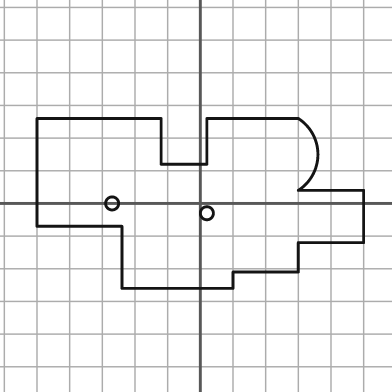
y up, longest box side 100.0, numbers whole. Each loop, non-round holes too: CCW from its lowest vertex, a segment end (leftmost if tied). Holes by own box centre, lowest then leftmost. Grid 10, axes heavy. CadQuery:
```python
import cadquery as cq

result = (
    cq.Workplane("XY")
    .moveTo(-24.0, -26.0)
    .lineTo(10.0, -26.0)
    .lineTo(10.0, -21.0)
    .lineTo(30.0, -21.0)
    .lineTo(30.0, -12.0)
    .lineTo(50.0, -12.0)
    .lineTo(50.0, 4.0)
    .lineTo(30.0, 4.0)
    .threePointArc((36.0, 15.0), (30.0, 26.0))
    .lineTo(2.0, 26.0)
    .lineTo(2.0, 12.0)
    .lineTo(-12.0, 12.0)
    .lineTo(-12.0, 26.0)
    .lineTo(-50.0, 26.0)
    .lineTo(-50.0, -7.0)
    .lineTo(-24.0, -7.0)
    .close()
    .moveTo(2.0, -3.0)
    .circle(2.0)
    .moveTo(-27.0, 0.0)
    .circle(2.0)
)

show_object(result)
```